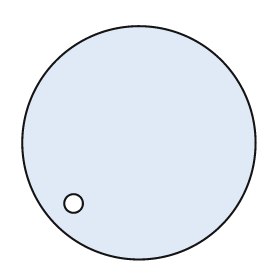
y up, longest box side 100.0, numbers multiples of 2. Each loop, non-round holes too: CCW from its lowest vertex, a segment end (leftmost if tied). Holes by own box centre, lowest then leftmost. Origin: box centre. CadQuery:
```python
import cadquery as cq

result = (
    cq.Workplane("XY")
    .moveTo(0.0, 0.0)
    .circle(50.0)
    .moveTo(-28.0, -26.0)
    .circle(4.0)
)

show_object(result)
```